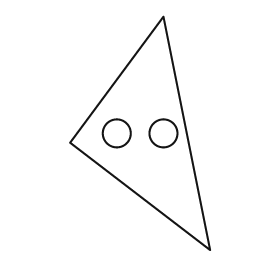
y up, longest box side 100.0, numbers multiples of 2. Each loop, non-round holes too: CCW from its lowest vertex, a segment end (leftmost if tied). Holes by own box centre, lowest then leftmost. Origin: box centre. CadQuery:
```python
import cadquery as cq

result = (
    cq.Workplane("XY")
    .moveTo(30.0, -50.0)
    .lineTo(10.0, 50.0)
    .lineTo(-30.0, -4.0)
    .close()
    .moveTo(-10.0, 0.0)
    .circle(6.0)
    .moveTo(10.0, 0.0)
    .circle(6.0)
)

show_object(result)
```